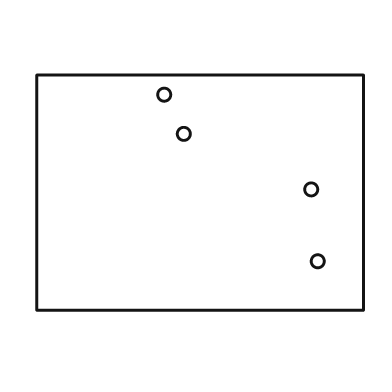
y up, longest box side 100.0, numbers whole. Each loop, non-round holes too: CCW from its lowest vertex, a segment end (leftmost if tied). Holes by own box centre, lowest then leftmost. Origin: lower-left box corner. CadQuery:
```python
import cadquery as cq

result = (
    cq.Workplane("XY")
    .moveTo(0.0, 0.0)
    .lineTo(100.0, 0.0)
    .lineTo(100.0, 72.0)
    .lineTo(0.0, 72.0)
    .close()
    .moveTo(86.0, 15.0)
    .circle(2.0)
    .moveTo(84.0, 37.0)
    .circle(2.0)
    .moveTo(45.0, 54.0)
    .circle(2.0)
    .moveTo(39.0, 66.0)
    .circle(2.0)
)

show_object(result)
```